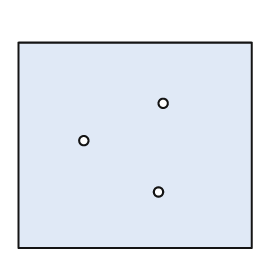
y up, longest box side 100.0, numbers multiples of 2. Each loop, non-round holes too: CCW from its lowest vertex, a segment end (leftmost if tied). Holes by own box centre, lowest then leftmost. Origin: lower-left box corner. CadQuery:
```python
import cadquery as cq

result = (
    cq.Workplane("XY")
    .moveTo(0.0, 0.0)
    .lineTo(100.0, 0.0)
    .lineTo(100.0, 88.0)
    .lineTo(0.0, 88.0)
    .close()
    .moveTo(60.0, 24.0)
    .circle(2.0)
    .moveTo(28.0, 46.0)
    .circle(2.0)
    .moveTo(62.0, 62.0)
    .circle(2.0)
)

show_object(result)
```